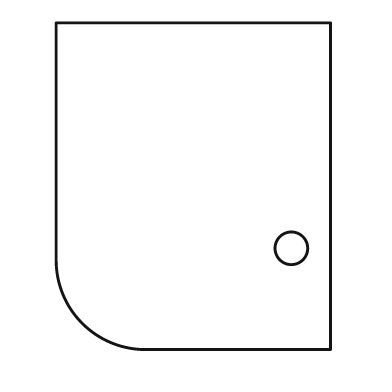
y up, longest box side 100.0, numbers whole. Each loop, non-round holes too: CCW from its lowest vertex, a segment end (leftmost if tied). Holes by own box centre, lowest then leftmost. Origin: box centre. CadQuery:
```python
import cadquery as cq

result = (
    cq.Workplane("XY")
    .moveTo(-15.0, -50.0)
    .lineTo(42.0, -50.0)
    .lineTo(42.0, 50.0)
    .lineTo(-42.0, 50.0)
    .lineTo(-42.0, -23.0)
    .threePointArc((-34.0, -42.0), (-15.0, -50.0))
    .close()
    .moveTo(30.0, -19.0)
    .circle(5.0)
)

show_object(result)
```